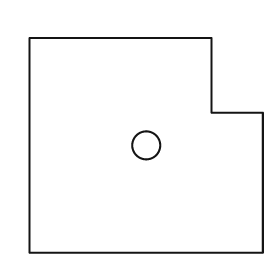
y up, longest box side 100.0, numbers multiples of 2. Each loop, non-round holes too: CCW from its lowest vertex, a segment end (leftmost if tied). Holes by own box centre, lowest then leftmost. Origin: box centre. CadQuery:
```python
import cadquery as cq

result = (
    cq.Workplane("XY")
    .moveTo(-50.0, -46.0)
    .lineTo(50.0, -46.0)
    .lineTo(50.0, 14.0)
    .lineTo(28.0, 14.0)
    .lineTo(28.0, 46.0)
    .lineTo(-50.0, 46.0)
    .close()
    .moveTo(0.0, 0.0)
    .circle(6.0)
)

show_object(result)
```